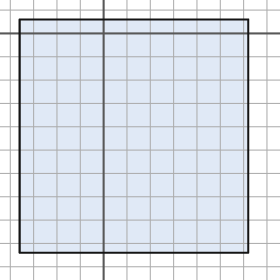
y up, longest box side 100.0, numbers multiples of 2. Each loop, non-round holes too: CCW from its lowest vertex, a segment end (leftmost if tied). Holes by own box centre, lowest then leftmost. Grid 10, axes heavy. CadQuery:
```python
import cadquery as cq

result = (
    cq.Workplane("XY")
    .moveTo(-36.0, -94.0)
    .lineTo(62.0, -94.0)
    .lineTo(62.0, 6.0)
    .lineTo(-36.0, 6.0)
    .close()
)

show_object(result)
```